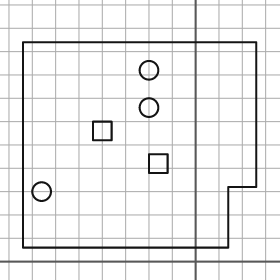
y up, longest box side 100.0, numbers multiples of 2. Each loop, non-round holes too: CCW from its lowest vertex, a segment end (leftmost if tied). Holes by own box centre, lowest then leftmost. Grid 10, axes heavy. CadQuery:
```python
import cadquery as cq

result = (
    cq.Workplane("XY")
    .moveTo(-74.0, 6.0)
    .lineTo(14.0, 6.0)
    .lineTo(14.0, 32.0)
    .lineTo(26.0, 32.0)
    .lineTo(26.0, 94.0)
    .lineTo(-74.0, 94.0)
    .close()
    .moveTo(-66.0, 30.0)
    .circle(4.0)
    .moveTo(-20.0, 38.0)
    .lineTo(-12.0, 38.0)
    .lineTo(-12.0, 46.0)
    .lineTo(-20.0, 46.0)
    .close()
    .moveTo(-44.0, 52.0)
    .lineTo(-36.0, 52.0)
    .lineTo(-36.0, 60.0)
    .lineTo(-44.0, 60.0)
    .close()
    .moveTo(-20.0, 66.0)
    .circle(4.0)
    .moveTo(-20.0, 82.0)
    .circle(4.0)
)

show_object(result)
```